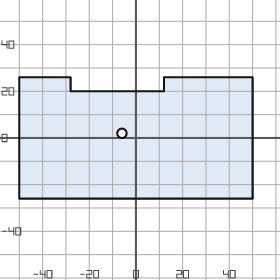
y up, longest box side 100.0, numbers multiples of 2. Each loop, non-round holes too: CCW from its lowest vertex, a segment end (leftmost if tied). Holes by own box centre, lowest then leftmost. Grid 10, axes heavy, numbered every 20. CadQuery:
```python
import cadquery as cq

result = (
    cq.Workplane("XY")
    .moveTo(-50.0, -26.0)
    .lineTo(50.0, -26.0)
    .lineTo(50.0, 26.0)
    .lineTo(12.0, 26.0)
    .lineTo(12.0, 20.0)
    .lineTo(-28.0, 20.0)
    .lineTo(-28.0, 26.0)
    .lineTo(-50.0, 26.0)
    .close()
    .moveTo(-6.0, 2.0)
    .circle(2.0)
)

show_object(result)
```